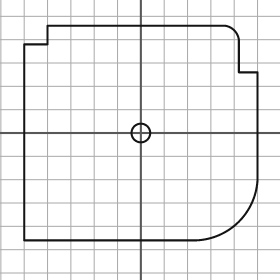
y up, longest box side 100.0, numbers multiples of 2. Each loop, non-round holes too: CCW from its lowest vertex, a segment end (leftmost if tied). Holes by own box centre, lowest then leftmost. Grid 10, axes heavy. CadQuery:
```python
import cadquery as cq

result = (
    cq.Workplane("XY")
    .moveTo(-50.0, -46.0)
    .lineTo(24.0, -46.0)
    .threePointArc((42.0, -38.0), (50.0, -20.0))
    .lineTo(50.0, 26.0)
    .lineTo(42.0, 26.0)
    .lineTo(42.0, 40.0)
    .threePointArc((40.0, 44.0), (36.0, 46.0))
    .lineTo(-40.0, 46.0)
    .lineTo(-40.0, 38.0)
    .lineTo(-50.0, 38.0)
    .close()
    .moveTo(0.0, 0.0)
    .circle(4.0)
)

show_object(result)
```